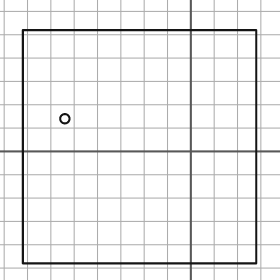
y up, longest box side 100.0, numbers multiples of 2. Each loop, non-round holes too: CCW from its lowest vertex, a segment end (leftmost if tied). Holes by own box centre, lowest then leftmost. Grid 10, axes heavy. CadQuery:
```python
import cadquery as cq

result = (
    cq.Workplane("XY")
    .moveTo(-72.0, -48.0)
    .lineTo(28.0, -48.0)
    .lineTo(28.0, 52.0)
    .lineTo(-72.0, 52.0)
    .close()
    .moveTo(-54.0, 14.0)
    .circle(2.0)
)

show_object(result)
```